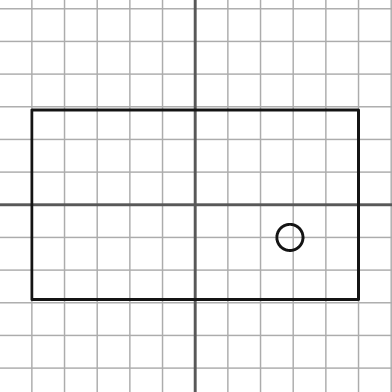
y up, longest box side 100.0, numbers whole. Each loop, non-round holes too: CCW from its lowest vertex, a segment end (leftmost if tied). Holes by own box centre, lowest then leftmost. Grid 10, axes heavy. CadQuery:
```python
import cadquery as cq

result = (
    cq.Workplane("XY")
    .moveTo(-50.0, -29.0)
    .lineTo(50.0, -29.0)
    .lineTo(50.0, 29.0)
    .lineTo(-50.0, 29.0)
    .close()
    .moveTo(29.0, -10.0)
    .circle(4.0)
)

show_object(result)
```